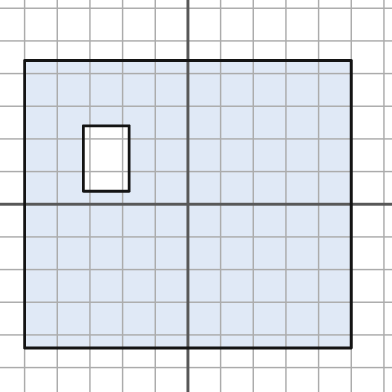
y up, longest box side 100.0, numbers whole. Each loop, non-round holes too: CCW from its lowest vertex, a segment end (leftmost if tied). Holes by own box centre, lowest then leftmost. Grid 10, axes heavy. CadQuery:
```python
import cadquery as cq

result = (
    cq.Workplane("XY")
    .moveTo(-50.0, -44.0)
    .lineTo(50.0, -44.0)
    .lineTo(50.0, 44.0)
    .lineTo(-50.0, 44.0)
    .close()
    .moveTo(-32.0, 4.0)
    .lineTo(-18.0, 4.0)
    .lineTo(-18.0, 24.0)
    .lineTo(-32.0, 24.0)
    .close()
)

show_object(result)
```